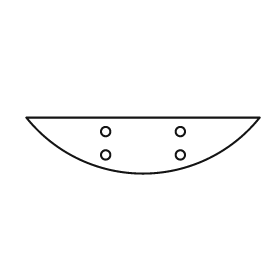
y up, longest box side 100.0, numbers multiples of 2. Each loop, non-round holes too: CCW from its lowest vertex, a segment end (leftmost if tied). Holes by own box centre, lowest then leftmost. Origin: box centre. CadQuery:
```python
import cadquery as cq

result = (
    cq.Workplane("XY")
    .moveTo(-50.0, 12.0)
    .threePointArc((0.0, -12.0), (50.0, 12.0))
    .close()
    .moveTo(-16.0, -4.0)
    .circle(2.0)
    .moveTo(16.0, -4.0)
    .circle(2.0)
    .moveTo(-16.0, 6.0)
    .circle(2.0)
    .moveTo(16.0, 6.0)
    .circle(2.0)
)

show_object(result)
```